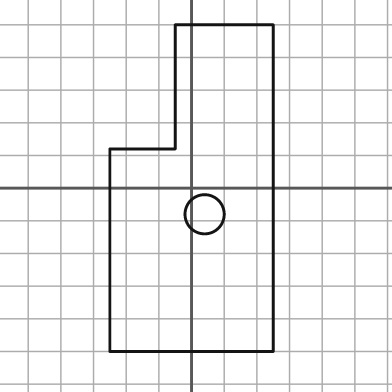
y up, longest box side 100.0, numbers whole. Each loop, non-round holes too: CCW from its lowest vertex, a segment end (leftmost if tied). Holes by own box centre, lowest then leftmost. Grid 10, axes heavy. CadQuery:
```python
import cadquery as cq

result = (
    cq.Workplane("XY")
    .moveTo(-25.0, -50.0)
    .lineTo(25.0, -50.0)
    .lineTo(25.0, 50.0)
    .lineTo(-5.0, 50.0)
    .lineTo(-5.0, 12.0)
    .lineTo(-25.0, 12.0)
    .close()
    .moveTo(4.0, -8.0)
    .circle(6.0)
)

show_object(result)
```